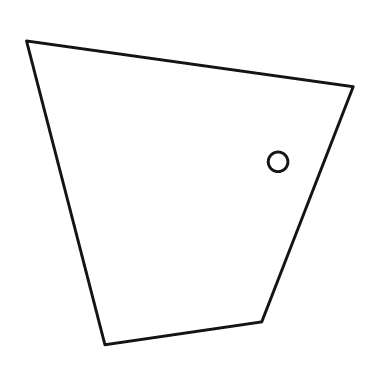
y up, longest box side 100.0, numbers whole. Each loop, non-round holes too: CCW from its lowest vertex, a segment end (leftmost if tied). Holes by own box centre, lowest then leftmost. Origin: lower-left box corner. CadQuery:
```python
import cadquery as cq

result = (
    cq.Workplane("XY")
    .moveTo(24.0, 0.0)
    .lineTo(72.0, 7.0)
    .lineTo(100.0, 79.0)
    .lineTo(0.0, 93.0)
    .close()
    .moveTo(77.0, 56.0)
    .circle(3.0)
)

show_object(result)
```